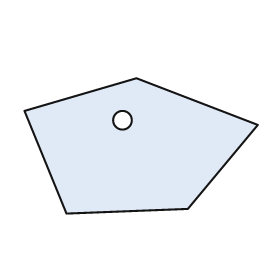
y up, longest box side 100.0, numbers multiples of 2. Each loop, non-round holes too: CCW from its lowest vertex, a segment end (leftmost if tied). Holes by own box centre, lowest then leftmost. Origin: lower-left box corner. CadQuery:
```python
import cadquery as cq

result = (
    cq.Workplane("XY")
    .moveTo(18.0, 0.0)
    .lineTo(70.0, 2.0)
    .lineTo(100.0, 38.0)
    .lineTo(48.0, 58.0)
    .lineTo(0.0, 44.0)
    .close()
    .moveTo(42.0, 40.0)
    .circle(4.0)
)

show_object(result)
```